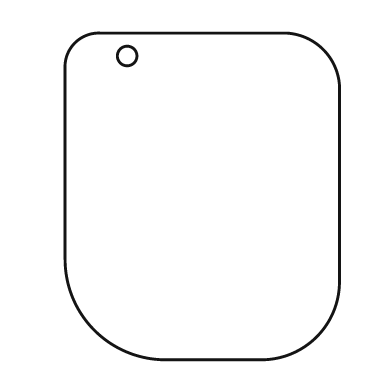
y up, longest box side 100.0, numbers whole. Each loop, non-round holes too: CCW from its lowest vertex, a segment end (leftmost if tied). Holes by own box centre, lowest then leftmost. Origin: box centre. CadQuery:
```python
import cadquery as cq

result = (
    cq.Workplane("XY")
    .moveTo(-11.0, -50.0)
    .lineTo(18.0, -50.0)
    .threePointArc((35.0, -43.0), (42.0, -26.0))
    .lineTo(42.0, 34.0)
    .threePointArc((37.0, 45.0), (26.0, 50.0))
    .lineTo(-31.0, 50.0)
    .threePointArc((-39.0, 47.0), (-42.0, 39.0))
    .lineTo(-42.0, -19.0)
    .threePointArc((-33.0, -41.0), (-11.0, -50.0))
    .close()
    .moveTo(-23.0, 43.0)
    .circle(3.0)
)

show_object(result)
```